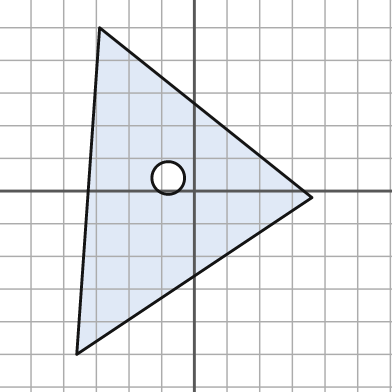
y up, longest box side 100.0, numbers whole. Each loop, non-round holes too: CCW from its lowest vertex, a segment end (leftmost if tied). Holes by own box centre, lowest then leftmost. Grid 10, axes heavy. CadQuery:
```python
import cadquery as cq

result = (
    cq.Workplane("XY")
    .moveTo(-36.0, -50.0)
    .lineTo(36.0, -2.0)
    .lineTo(-29.0, 50.0)
    .close()
    .moveTo(-8.0, 4.0)
    .circle(5.0)
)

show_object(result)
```